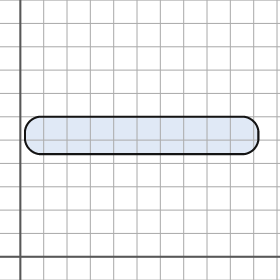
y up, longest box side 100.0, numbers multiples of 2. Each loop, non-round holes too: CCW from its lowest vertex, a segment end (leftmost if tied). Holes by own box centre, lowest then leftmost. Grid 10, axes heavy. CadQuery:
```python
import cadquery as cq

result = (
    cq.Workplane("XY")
    .moveTo(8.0, 44.0)
    .lineTo(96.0, 44.0)
    .threePointArc((100.0, 46.0), (102.0, 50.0))
    .lineTo(102.0, 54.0)
    .threePointArc((100.0, 58.0), (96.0, 60.0))
    .lineTo(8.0, 60.0)
    .threePointArc((4.0, 58.0), (2.0, 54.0))
    .lineTo(2.0, 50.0)
    .threePointArc((4.0, 46.0), (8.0, 44.0))
    .close()
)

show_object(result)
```